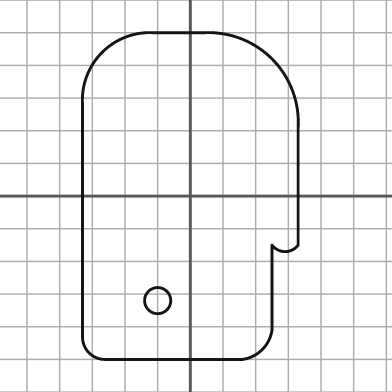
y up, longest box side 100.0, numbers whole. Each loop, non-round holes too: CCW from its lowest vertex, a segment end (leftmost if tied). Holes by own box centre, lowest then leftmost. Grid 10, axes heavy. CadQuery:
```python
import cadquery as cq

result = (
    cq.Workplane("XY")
    .moveTo(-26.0, -50.0)
    .lineTo(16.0, -50.0)
    .threePointArc((22.0, -47.0), (25.0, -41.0))
    .lineTo(25.0, -15.0)
    .threePointArc((29.0, -17.0), (33.0, -15.0))
    .lineTo(33.0, 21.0)
    .threePointArc((25.0, 42.0), (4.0, 50.0))
    .lineTo(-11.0, 50.0)
    .threePointArc((-27.0, 44.0), (-33.0, 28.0))
    .lineTo(-33.0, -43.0)
    .threePointArc((-31.0, -48.0), (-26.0, -50.0))
    .close()
    .moveTo(-10.0, -32.0)
    .circle(4.0)
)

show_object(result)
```